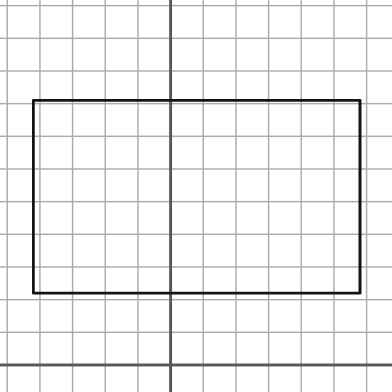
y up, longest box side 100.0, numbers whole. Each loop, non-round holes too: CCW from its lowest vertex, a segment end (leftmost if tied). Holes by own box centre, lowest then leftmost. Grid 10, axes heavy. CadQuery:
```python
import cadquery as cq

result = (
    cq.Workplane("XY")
    .moveTo(-42.0, 22.0)
    .lineTo(58.0, 22.0)
    .lineTo(58.0, 81.0)
    .lineTo(-42.0, 81.0)
    .close()
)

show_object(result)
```